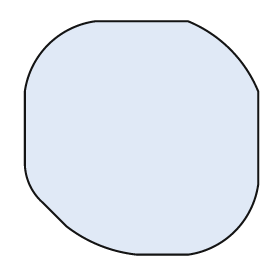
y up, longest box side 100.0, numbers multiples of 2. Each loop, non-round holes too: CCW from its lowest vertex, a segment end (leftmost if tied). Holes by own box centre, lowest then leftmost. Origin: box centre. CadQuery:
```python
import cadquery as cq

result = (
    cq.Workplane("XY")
    .moveTo(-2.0, -50.0)
    .lineTo(20.0, -50.0)
    .threePointArc((40.0, -40.0), (50.0, -20.0))
    .lineTo(50.0, 20.0)
    .threePointArc((38.0, 38.0), (20.0, 50.0))
    .lineTo(-20.0, 50.0)
    .threePointArc((-40.0, 40.0), (-50.0, 20.0))
    .lineTo(-50.0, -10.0)
    .threePointArc((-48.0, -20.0), (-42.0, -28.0))
    .lineTo(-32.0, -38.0)
    .threePointArc((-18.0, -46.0), (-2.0, -50.0))
    .close()
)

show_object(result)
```